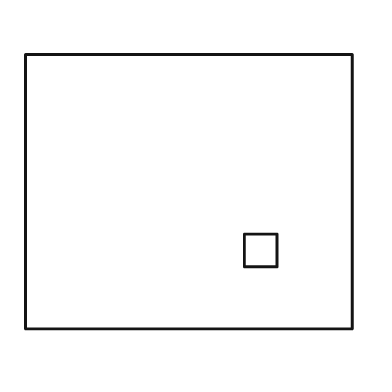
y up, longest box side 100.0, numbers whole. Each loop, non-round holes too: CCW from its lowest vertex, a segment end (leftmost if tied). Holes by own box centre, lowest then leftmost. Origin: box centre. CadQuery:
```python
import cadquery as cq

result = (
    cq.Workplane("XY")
    .moveTo(-50.0, -42.0)
    .lineTo(50.0, -42.0)
    .lineTo(50.0, 42.0)
    .lineTo(-50.0, 42.0)
    .close()
    .moveTo(17.0, -23.0)
    .lineTo(27.0, -23.0)
    .lineTo(27.0, -13.0)
    .lineTo(17.0, -13.0)
    .close()
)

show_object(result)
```